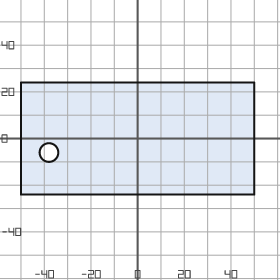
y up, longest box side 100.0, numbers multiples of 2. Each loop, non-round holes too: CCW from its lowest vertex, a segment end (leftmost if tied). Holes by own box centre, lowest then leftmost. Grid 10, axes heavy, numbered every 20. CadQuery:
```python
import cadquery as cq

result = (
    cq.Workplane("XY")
    .moveTo(-50.0, -24.0)
    .lineTo(50.0, -24.0)
    .lineTo(50.0, 24.0)
    .lineTo(-50.0, 24.0)
    .close()
    .moveTo(-38.0, -6.0)
    .circle(4.0)
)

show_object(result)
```